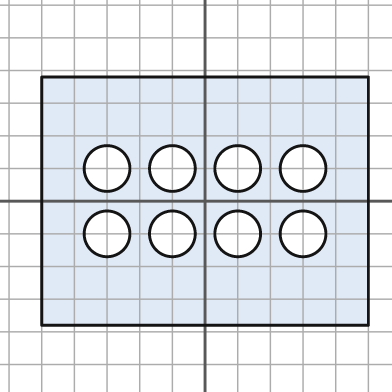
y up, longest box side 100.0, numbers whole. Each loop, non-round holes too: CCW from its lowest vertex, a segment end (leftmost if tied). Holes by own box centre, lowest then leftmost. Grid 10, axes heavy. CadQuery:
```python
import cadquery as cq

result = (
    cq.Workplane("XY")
    .moveTo(-50.0, -38.0)
    .lineTo(50.0, -38.0)
    .lineTo(50.0, 38.0)
    .lineTo(-50.0, 38.0)
    .close()
    .moveTo(-30.0, -10.0)
    .circle(7.0)
    .moveTo(-10.0, -10.0)
    .circle(7.0)
    .moveTo(10.0, -10.0)
    .circle(7.0)
    .moveTo(30.0, -10.0)
    .circle(7.0)
    .moveTo(-30.0, 10.0)
    .circle(7.0)
    .moveTo(-10.0, 10.0)
    .circle(7.0)
    .moveTo(10.0, 10.0)
    .circle(7.0)
    .moveTo(30.0, 10.0)
    .circle(7.0)
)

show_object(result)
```